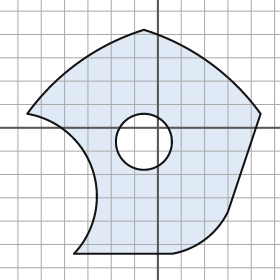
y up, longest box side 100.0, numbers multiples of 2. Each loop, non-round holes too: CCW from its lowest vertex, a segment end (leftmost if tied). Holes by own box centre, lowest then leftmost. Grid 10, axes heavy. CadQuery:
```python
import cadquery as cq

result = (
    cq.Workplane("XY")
    .moveTo(-36.0, -54.0)
    .lineTo(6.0, -54.0)
    .threePointArc((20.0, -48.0), (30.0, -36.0))
    .lineTo(44.0, 6.0)
    .threePointArc((22.0, 28.0), (-6.0, 42.0))
    .threePointArc((-34.0, 28.0), (-56.0, 6.0))
    .threePointArc((-28.0, -18.0), (-36.0, -54.0))
    .close()
    .moveTo(-6.0, -6.0)
    .circle(12.0)
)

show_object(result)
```